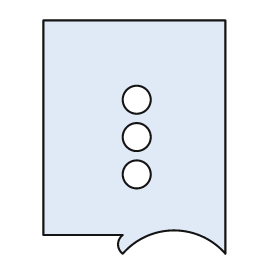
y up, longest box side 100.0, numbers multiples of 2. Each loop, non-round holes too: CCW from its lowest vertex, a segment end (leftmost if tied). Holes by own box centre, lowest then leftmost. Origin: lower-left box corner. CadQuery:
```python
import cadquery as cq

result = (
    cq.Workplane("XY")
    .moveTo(34.0, 0.0)
    .threePointArc((56.0, 10.0), (78.0, 0.0))
    .lineTo(78.0, 100.0)
    .lineTo(0.0, 100.0)
    .lineTo(0.0, 8.0)
    .lineTo(34.0, 8.0)
    .threePointArc((32.0, 4.0), (34.0, 0.0))
    .close()
    .moveTo(40.0, 34.0)
    .circle(6.0)
    .moveTo(40.0, 50.0)
    .circle(6.0)
    .moveTo(40.0, 66.0)
    .circle(6.0)
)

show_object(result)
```